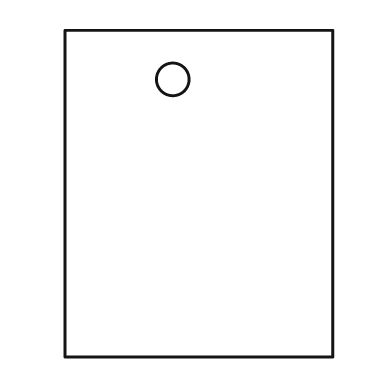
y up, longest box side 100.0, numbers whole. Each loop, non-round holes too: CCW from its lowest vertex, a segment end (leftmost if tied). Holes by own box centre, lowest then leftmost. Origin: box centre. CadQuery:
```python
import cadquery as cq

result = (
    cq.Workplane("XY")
    .moveTo(-41.0, -50.0)
    .lineTo(41.0, -50.0)
    .lineTo(41.0, 50.0)
    .lineTo(-41.0, 50.0)
    .close()
    .moveTo(-8.0, 35.0)
    .circle(5.0)
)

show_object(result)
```